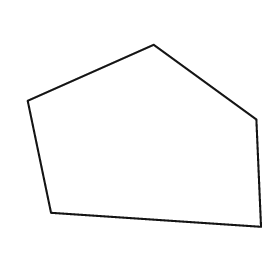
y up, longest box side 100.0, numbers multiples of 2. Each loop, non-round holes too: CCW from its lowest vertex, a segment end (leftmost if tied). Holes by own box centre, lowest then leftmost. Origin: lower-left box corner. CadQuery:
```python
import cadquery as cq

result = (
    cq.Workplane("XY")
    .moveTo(100.0, 0.0)
    .lineTo(98.0, 46.0)
    .lineTo(54.0, 78.0)
    .lineTo(0.0, 54.0)
    .lineTo(10.0, 6.0)
    .close()
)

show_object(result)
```